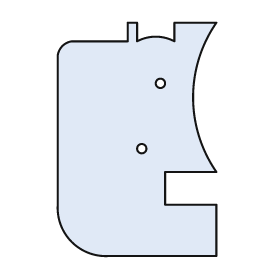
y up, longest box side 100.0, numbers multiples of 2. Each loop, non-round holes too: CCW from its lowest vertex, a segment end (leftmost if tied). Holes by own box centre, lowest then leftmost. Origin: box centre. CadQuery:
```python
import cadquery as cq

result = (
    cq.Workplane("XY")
    .moveTo(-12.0, -50.0)
    .lineTo(34.0, -50.0)
    .lineTo(34.0, -28.0)
    .lineTo(12.0, -28.0)
    .lineTo(12.0, -14.0)
    .lineTo(34.0, -14.0)
    .threePointArc((24.0, 18.0), (34.0, 50.0))
    .lineTo(16.0, 50.0)
    .lineTo(16.0, 42.0)
    .threePointArc((8.0, 44.0), (0.0, 42.0))
    .lineTo(0.0, 50.0)
    .lineTo(-4.0, 50.0)
    .lineTo(-4.0, 42.0)
    .lineTo(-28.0, 42.0)
    .threePointArc((-32.0, 40.0), (-34.0, 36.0))
    .lineTo(-34.0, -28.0)
    .threePointArc((-28.0, -44.0), (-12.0, -50.0))
    .close()
    .moveTo(2.0, -4.0)
    .circle(2.0)
    .moveTo(10.0, 24.0)
    .circle(2.0)
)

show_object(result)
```